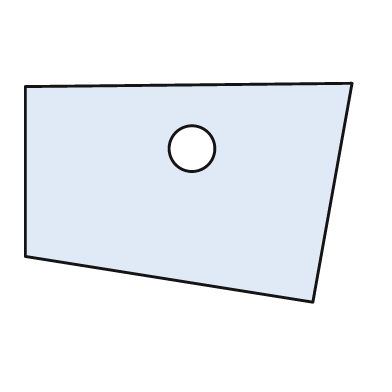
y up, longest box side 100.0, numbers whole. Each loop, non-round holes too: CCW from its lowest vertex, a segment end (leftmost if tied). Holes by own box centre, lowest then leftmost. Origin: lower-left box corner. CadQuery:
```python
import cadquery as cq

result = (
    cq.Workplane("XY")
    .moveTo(88.0, 0.0)
    .lineTo(100.0, 67.0)
    .lineTo(0.0, 66.0)
    .lineTo(0.0, 14.0)
    .close()
    .moveTo(51.0, 47.0)
    .circle(7.0)
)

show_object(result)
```